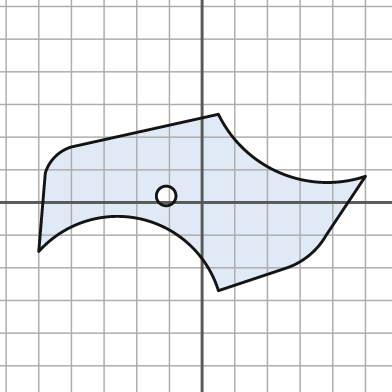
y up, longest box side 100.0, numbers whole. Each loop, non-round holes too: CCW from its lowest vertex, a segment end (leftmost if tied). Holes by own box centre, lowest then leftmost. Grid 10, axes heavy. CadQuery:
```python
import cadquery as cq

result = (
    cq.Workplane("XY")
    .moveTo(5.0, -27.0)
    .lineTo(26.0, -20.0)
    .threePointArc((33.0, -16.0), (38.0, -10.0))
    .lineTo(50.0, 8.0)
    .threePointArc((24.0, 9.0), (5.0, 27.0))
    .lineTo(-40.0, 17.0)
    .threePointArc((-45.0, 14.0), (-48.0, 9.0))
    .lineTo(-50.0, -15.0)
    .threePointArc((-19.0, -5.0), (5.0, -27.0))
    .close()
    .moveTo(-11.0, 2.0)
    .circle(3.0)
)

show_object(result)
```